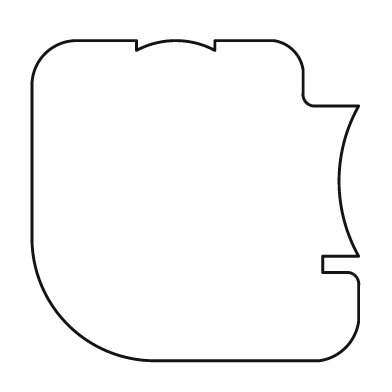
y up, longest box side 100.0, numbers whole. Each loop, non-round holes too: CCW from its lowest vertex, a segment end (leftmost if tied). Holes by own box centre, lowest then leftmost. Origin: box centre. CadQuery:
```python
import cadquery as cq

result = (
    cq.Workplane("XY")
    .moveTo(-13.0, -49.0)
    .lineTo(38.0, -49.0)
    .threePointArc((46.0, -45.0), (50.0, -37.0))
    .lineTo(50.0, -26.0)
    .threePointArc((49.0, -23.0), (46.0, -22.0))
    .lineTo(39.0, -22.0)
    .lineTo(39.0, -17.0)
    .lineTo(50.0, -17.0)
    .threePointArc((44.0, 6.0), (50.0, 29.0))
    .lineTo(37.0, 29.0)
    .threePointArc((34.0, 30.0), (33.0, 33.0))
    .lineTo(33.0, 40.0)
    .threePointArc((30.0, 46.0), (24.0, 49.0))
    .lineTo(6.0, 49.0)
    .lineTo(6.0, 46.0)
    .threePointArc((-6.0, 49.0), (-18.0, 46.0))
    .lineTo(-18.0, 49.0)
    .lineTo(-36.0, 49.0)
    .threePointArc((-46.0, 45.0), (-50.0, 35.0))
    .lineTo(-50.0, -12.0)
    .threePointArc((-39.0, -38.0), (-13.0, -49.0))
    .close()
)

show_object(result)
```